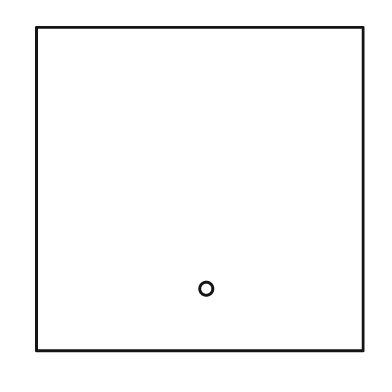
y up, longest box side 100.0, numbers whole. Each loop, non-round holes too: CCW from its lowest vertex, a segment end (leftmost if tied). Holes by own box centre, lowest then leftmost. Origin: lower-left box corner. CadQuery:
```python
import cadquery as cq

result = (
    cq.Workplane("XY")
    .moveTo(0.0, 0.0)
    .lineTo(100.0, 0.0)
    .lineTo(100.0, 99.0)
    .lineTo(0.0, 99.0)
    .close()
    .moveTo(52.0, 19.0)
    .circle(2.0)
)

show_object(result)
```